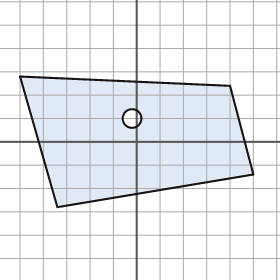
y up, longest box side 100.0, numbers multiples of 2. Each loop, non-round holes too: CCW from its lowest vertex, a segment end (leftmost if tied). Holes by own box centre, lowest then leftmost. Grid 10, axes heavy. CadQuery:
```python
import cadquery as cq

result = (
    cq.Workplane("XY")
    .moveTo(-34.0, -28.0)
    .lineTo(50.0, -14.0)
    .lineTo(40.0, 24.0)
    .lineTo(-50.0, 28.0)
    .close()
    .moveTo(-2.0, 10.0)
    .circle(4.0)
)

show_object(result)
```